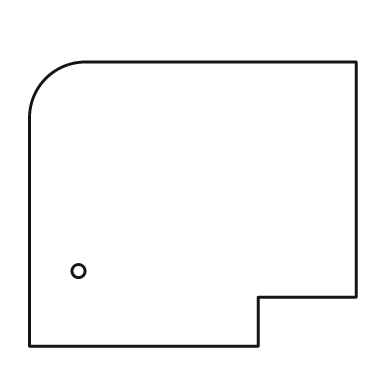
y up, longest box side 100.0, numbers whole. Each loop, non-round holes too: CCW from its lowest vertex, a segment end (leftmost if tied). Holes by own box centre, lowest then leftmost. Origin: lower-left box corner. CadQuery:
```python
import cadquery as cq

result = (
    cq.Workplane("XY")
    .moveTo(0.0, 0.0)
    .lineTo(70.0, 0.0)
    .lineTo(70.0, 15.0)
    .lineTo(100.0, 15.0)
    .lineTo(100.0, 87.0)
    .lineTo(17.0, 87.0)
    .threePointArc((5.0, 82.0), (0.0, 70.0))
    .close()
    .moveTo(15.0, 23.0)
    .circle(2.0)
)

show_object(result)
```